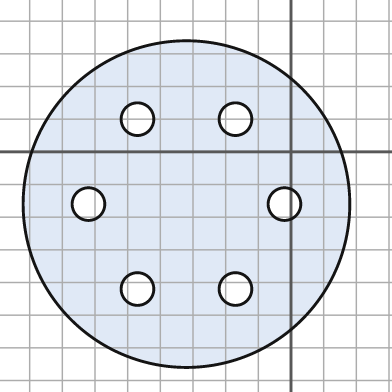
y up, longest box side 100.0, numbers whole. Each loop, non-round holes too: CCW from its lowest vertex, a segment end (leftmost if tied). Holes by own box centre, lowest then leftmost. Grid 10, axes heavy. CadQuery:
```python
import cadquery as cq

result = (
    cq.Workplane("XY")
    .moveTo(-32.0, -16.0)
    .circle(50.0)
    .moveTo(-47.0, -42.0)
    .circle(5.0)
    .moveTo(-17.0, -42.0)
    .circle(5.0)
    .moveTo(-62.0, -16.0)
    .circle(5.0)
    .moveTo(-2.0, -16.0)
    .circle(5.0)
    .moveTo(-47.0, 10.0)
    .circle(5.0)
    .moveTo(-17.0, 10.0)
    .circle(5.0)
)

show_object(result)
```